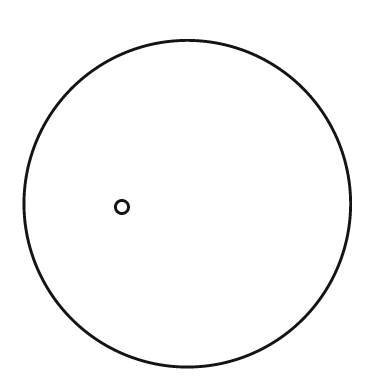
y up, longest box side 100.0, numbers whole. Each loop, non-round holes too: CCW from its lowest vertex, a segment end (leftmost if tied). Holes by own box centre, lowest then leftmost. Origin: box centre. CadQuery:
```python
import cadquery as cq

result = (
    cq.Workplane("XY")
    .moveTo(0.0, 0.0)
    .circle(50.0)
    .moveTo(-20.0, -1.0)
    .circle(2.0)
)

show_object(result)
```